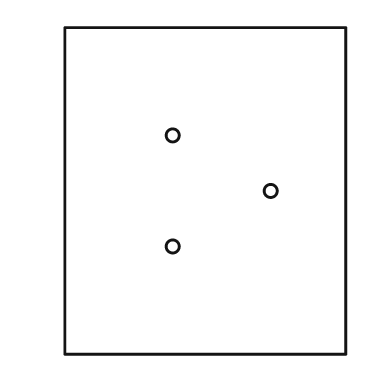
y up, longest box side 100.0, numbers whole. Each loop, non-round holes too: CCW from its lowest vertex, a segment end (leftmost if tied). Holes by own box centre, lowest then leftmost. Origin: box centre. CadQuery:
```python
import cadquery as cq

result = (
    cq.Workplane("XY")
    .moveTo(-43.0, -50.0)
    .lineTo(43.0, -50.0)
    .lineTo(43.0, 50.0)
    .lineTo(-43.0, 50.0)
    .close()
    .moveTo(-10.0, -17.0)
    .circle(2.0)
    .moveTo(20.0, 0.0)
    .circle(2.0)
    .moveTo(-10.0, 17.0)
    .circle(2.0)
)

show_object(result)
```